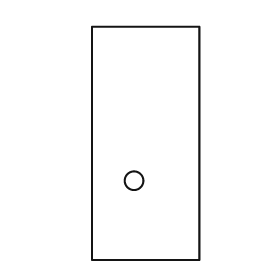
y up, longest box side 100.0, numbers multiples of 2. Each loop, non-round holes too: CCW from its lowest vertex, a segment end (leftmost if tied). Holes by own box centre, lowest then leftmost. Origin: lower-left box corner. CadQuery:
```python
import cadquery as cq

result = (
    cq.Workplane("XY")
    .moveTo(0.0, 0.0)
    .lineTo(46.0, 0.0)
    .lineTo(46.0, 100.0)
    .lineTo(0.0, 100.0)
    .close()
    .moveTo(18.0, 34.0)
    .circle(4.0)
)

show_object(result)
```